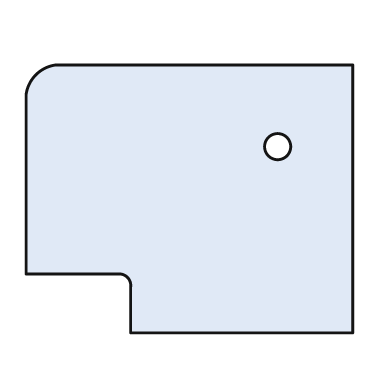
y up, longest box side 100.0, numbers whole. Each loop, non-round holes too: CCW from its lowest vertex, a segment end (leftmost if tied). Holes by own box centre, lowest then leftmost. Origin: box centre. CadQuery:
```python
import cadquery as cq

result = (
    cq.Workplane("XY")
    .moveTo(-18.0, -41.0)
    .lineTo(50.0, -41.0)
    .lineTo(50.0, 41.0)
    .lineTo(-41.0, 41.0)
    .threePointArc((-47.0, 38.0), (-50.0, 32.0))
    .lineTo(-50.0, -23.0)
    .lineTo(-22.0, -23.0)
    .threePointArc((-19.0, -24.0), (-18.0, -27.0))
    .close()
    .moveTo(27.0, 16.0)
    .circle(4.0)
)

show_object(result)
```